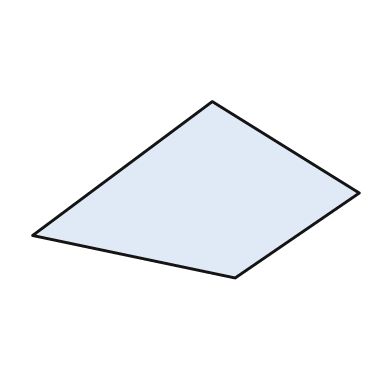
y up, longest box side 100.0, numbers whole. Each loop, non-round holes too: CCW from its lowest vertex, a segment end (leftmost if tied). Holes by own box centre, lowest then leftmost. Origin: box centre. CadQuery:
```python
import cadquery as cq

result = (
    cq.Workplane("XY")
    .moveTo(12.0, -27.0)
    .lineTo(50.0, -1.0)
    .lineTo(5.0, 27.0)
    .lineTo(-50.0, -14.0)
    .close()
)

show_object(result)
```